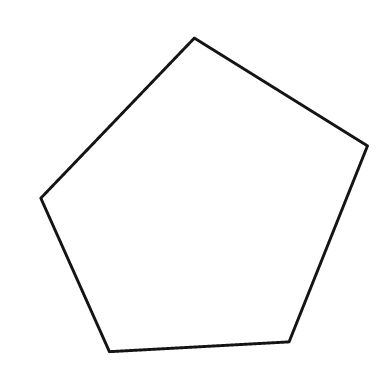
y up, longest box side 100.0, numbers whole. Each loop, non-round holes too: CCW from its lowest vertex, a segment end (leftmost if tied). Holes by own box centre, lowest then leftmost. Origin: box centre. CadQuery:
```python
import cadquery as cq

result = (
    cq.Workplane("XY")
    .moveTo(-29.0, -48.0)
    .lineTo(26.0, -45.0)
    .lineTo(50.0, 15.0)
    .lineTo(-3.0, 48.0)
    .lineTo(-50.0, -1.0)
    .close()
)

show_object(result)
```